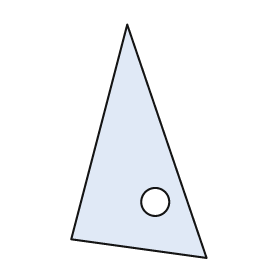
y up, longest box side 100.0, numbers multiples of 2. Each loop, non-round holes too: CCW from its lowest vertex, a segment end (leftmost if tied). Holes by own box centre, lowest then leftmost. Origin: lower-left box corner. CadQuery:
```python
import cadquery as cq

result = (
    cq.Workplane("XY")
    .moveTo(58.0, 0.0)
    .lineTo(24.0, 100.0)
    .lineTo(0.0, 8.0)
    .close()
    .moveTo(36.0, 24.0)
    .circle(6.0)
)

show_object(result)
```